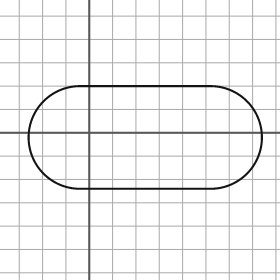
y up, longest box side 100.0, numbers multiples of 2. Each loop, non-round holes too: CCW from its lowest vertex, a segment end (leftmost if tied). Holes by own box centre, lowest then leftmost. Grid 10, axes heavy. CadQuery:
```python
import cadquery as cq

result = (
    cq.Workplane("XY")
    .moveTo(-4.0, -24.0)
    .lineTo(52.0, -24.0)
    .threePointArc((74.0, -2.0), (52.0, 20.0))
    .lineTo(-4.0, 20.0)
    .threePointArc((-26.0, -2.0), (-4.0, -24.0))
    .close()
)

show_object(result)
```